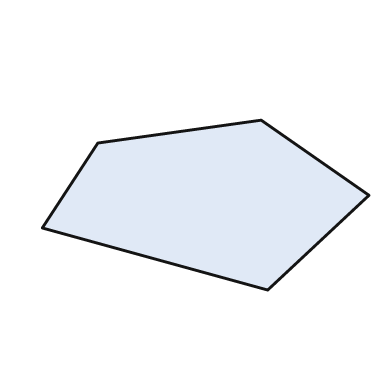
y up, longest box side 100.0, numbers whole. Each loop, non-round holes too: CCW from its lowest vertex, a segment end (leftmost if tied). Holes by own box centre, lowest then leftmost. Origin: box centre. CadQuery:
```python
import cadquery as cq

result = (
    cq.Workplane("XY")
    .moveTo(19.0, -26.0)
    .lineTo(50.0, 3.0)
    .lineTo(17.0, 26.0)
    .lineTo(-33.0, 19.0)
    .lineTo(-50.0, -7.0)
    .close()
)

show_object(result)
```